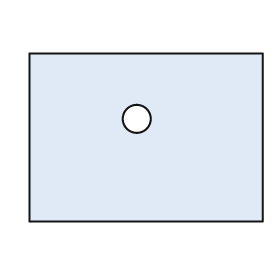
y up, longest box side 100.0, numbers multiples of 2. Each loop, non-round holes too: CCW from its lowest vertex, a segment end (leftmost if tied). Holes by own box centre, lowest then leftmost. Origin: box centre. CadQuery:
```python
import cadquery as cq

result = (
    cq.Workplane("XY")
    .moveTo(-50.0, -36.0)
    .lineTo(50.0, -36.0)
    .lineTo(50.0, 36.0)
    .lineTo(-50.0, 36.0)
    .close()
    .moveTo(-4.0, 8.0)
    .circle(6.0)
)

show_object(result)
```